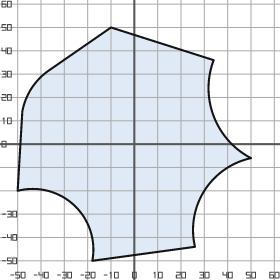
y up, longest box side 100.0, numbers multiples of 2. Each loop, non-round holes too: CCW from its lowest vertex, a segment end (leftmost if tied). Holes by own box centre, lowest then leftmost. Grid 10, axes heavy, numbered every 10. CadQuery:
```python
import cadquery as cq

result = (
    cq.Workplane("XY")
    .moveTo(-18.0, -50.0)
    .lineTo(26.0, -44.0)
    .threePointArc((30.0, -20.0), (50.0, -6.0))
    .threePointArc((34.0, 12.0), (34.0, 36.0))
    .lineTo(-10.0, 50.0)
    .lineTo(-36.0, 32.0)
    .threePointArc((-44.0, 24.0), (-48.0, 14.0))
    .lineTo(-50.0, -20.0)
    .threePointArc((-26.0, -26.0), (-18.0, -50.0))
    .close()
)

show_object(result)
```